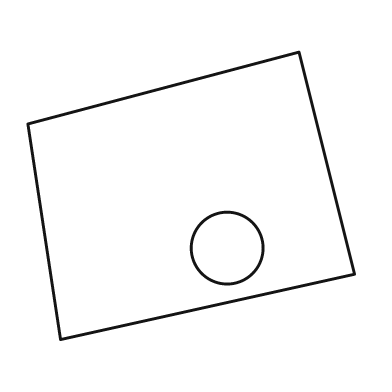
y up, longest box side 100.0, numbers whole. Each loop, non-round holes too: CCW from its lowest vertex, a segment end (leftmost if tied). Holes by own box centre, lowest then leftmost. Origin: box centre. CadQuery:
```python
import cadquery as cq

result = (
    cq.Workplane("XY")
    .moveTo(-40.0, -44.0)
    .lineTo(50.0, -24.0)
    .lineTo(33.0, 44.0)
    .lineTo(-50.0, 22.0)
    .close()
    .moveTo(11.0, -16.0)
    .circle(11.0)
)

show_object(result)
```